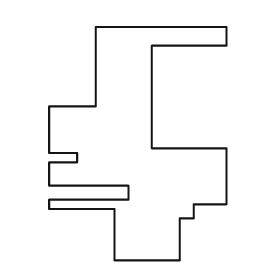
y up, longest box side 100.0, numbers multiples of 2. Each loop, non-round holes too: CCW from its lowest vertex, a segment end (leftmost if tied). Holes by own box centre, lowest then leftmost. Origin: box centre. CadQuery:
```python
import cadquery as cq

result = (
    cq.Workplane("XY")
    .moveTo(-10.0, -50.0)
    .lineTo(18.0, -50.0)
    .lineTo(18.0, -32.0)
    .lineTo(24.0, -32.0)
    .lineTo(24.0, -26.0)
    .lineTo(38.0, -26.0)
    .lineTo(38.0, -2.0)
    .lineTo(6.0, -2.0)
    .lineTo(6.0, 42.0)
    .lineTo(38.0, 42.0)
    .lineTo(38.0, 50.0)
    .lineTo(-18.0, 50.0)
    .lineTo(-18.0, 16.0)
    .lineTo(-38.0, 16.0)
    .lineTo(-38.0, -4.0)
    .lineTo(-26.0, -4.0)
    .lineTo(-26.0, -8.0)
    .lineTo(-38.0, -8.0)
    .lineTo(-38.0, -18.0)
    .lineTo(-4.0, -18.0)
    .lineTo(-4.0, -24.0)
    .lineTo(-38.0, -24.0)
    .lineTo(-38.0, -28.0)
    .lineTo(-10.0, -28.0)
    .close()
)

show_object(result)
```